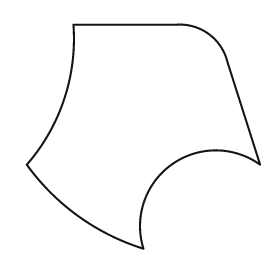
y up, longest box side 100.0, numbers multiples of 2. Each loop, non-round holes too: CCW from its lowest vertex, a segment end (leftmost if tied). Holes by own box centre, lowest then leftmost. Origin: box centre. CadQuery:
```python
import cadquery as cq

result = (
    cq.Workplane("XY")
    .moveTo(0.0, -48.0)
    .threePointArc((12.0, -12.0), (50.0, -12.0))
    .lineTo(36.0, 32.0)
    .threePointArc((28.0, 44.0), (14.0, 48.0))
    .lineTo(-30.0, 48.0)
    .threePointArc((-34.0, 16.0), (-50.0, -12.0))
    .threePointArc((-28.0, -34.0), (0.0, -48.0))
    .close()
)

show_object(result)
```